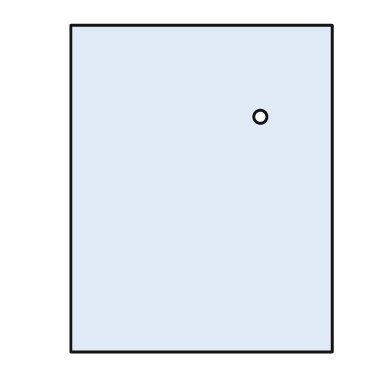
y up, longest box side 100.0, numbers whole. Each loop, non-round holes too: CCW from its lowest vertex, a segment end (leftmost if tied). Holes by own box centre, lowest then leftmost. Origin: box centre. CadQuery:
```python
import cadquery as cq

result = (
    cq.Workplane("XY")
    .moveTo(-40.0, -50.0)
    .lineTo(40.0, -50.0)
    .lineTo(40.0, 50.0)
    .lineTo(-40.0, 50.0)
    .close()
    .moveTo(18.0, 22.0)
    .circle(2.0)
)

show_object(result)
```